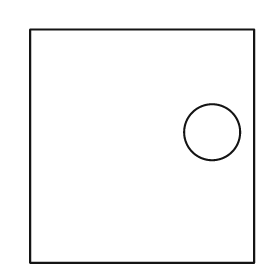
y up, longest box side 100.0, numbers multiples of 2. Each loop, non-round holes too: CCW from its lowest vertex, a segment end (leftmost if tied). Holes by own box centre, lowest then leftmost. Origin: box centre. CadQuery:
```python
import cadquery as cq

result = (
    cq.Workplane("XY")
    .moveTo(-48.0, -50.0)
    .lineTo(48.0, -50.0)
    .lineTo(48.0, 50.0)
    .lineTo(-48.0, 50.0)
    .close()
    .moveTo(30.0, 6.0)
    .circle(12.0)
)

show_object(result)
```